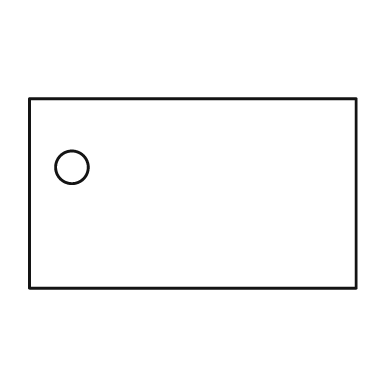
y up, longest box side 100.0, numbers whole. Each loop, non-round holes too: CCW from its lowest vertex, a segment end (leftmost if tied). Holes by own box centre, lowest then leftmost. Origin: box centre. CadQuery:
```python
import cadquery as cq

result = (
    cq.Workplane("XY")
    .moveTo(-50.0, -29.0)
    .lineTo(50.0, -29.0)
    .lineTo(50.0, 29.0)
    .lineTo(-50.0, 29.0)
    .close()
    .moveTo(-37.0, 8.0)
    .circle(5.0)
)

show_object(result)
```